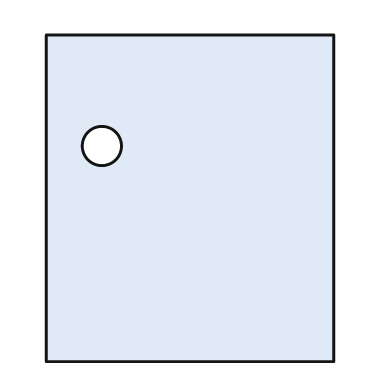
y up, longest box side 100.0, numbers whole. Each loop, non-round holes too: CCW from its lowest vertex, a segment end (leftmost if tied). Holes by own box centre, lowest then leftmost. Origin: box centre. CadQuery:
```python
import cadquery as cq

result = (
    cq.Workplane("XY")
    .moveTo(-44.0, -50.0)
    .lineTo(44.0, -50.0)
    .lineTo(44.0, 50.0)
    .lineTo(-44.0, 50.0)
    .close()
    .moveTo(-27.0, 16.0)
    .circle(6.0)
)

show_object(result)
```